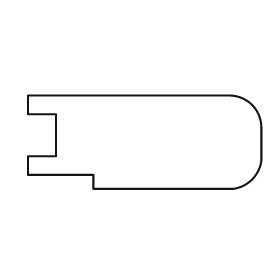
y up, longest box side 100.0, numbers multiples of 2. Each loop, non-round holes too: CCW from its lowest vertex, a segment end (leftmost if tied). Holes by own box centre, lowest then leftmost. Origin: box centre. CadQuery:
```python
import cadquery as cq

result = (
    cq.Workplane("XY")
    .moveTo(-22.0, -20.0)
    .lineTo(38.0, -20.0)
    .threePointArc((46.0, -16.0), (50.0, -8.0))
    .lineTo(50.0, 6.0)
    .threePointArc((46.0, 16.0), (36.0, 20.0))
    .lineTo(-50.0, 20.0)
    .lineTo(-50.0, 12.0)
    .lineTo(-38.0, 12.0)
    .lineTo(-38.0, -6.0)
    .lineTo(-50.0, -6.0)
    .lineTo(-50.0, -14.0)
    .lineTo(-22.0, -14.0)
    .close()
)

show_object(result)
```